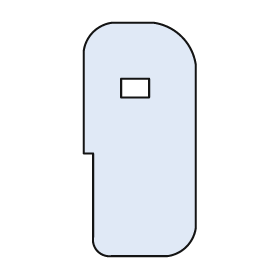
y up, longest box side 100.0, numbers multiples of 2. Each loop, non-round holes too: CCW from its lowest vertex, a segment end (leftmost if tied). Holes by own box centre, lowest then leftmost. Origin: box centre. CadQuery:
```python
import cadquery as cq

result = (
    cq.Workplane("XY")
    .moveTo(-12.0, -50.0)
    .lineTo(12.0, -50.0)
    .threePointArc((20.0, -46.0), (24.0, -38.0))
    .lineTo(24.0, 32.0)
    .threePointArc((18.0, 44.0), (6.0, 50.0))
    .lineTo(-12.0, 50.0)
    .threePointArc((-20.0, 46.0), (-24.0, 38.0))
    .lineTo(-24.0, -6.0)
    .lineTo(-20.0, -6.0)
    .lineTo(-20.0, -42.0)
    .threePointArc((-18.0, -48.0), (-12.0, -50.0))
    .close()
    .moveTo(-8.0, 18.0)
    .lineTo(4.0, 18.0)
    .lineTo(4.0, 26.0)
    .lineTo(-8.0, 26.0)
    .close()
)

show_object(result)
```